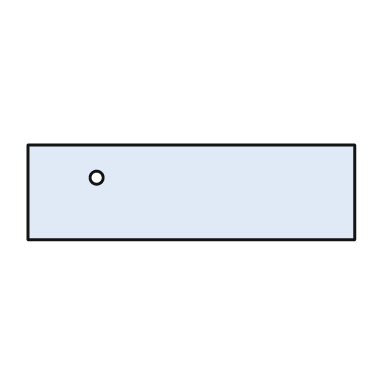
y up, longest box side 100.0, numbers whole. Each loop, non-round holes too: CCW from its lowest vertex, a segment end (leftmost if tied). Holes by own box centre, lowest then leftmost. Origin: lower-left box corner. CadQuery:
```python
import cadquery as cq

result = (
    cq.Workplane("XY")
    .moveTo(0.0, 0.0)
    .lineTo(100.0, 0.0)
    .lineTo(100.0, 29.0)
    .lineTo(0.0, 29.0)
    .close()
    .moveTo(21.0, 19.0)
    .circle(2.0)
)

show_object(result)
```